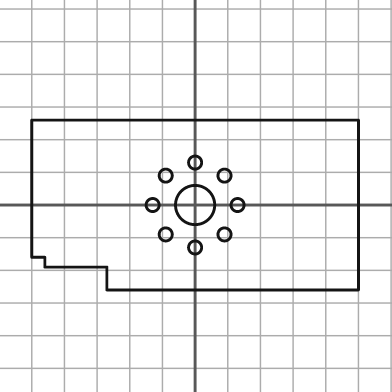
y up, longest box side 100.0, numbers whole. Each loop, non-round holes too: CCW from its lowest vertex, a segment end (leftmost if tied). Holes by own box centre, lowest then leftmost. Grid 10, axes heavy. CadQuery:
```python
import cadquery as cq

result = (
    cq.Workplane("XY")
    .moveTo(-27.0, -26.0)
    .lineTo(50.0, -26.0)
    .lineTo(50.0, 26.0)
    .lineTo(-50.0, 26.0)
    .lineTo(-50.0, -16.0)
    .lineTo(-46.0, -16.0)
    .lineTo(-46.0, -19.0)
    .lineTo(-27.0, -19.0)
    .close()
    .moveTo(0.0, -13.0)
    .circle(2.0)
    .moveTo(-9.0, -9.0)
    .circle(2.0)
    .moveTo(9.0, -9.0)
    .circle(2.0)
    .moveTo(-13.0, 0.0)
    .circle(2.0)
    .moveTo(0.0, 0.0)
    .circle(6.0)
    .moveTo(13.0, 0.0)
    .circle(2.0)
    .moveTo(-9.0, 9.0)
    .circle(2.0)
    .moveTo(9.0, 9.0)
    .circle(2.0)
    .moveTo(0.0, 13.0)
    .circle(2.0)
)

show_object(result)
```